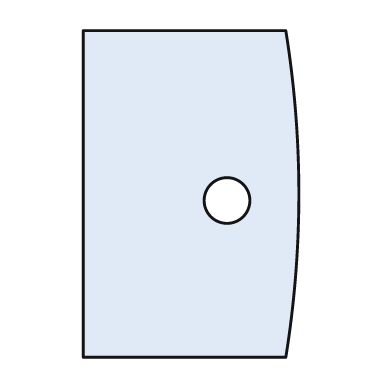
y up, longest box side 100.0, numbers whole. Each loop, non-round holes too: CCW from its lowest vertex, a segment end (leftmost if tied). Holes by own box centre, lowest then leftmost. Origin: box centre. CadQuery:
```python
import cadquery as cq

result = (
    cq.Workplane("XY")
    .moveTo(-33.0, -50.0)
    .lineTo(29.0, -50.0)
    .threePointArc((33.0, 0.0), (29.0, 50.0))
    .lineTo(-33.0, 50.0)
    .close()
    .moveTo(11.0, -2.0)
    .circle(7.0)
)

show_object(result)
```